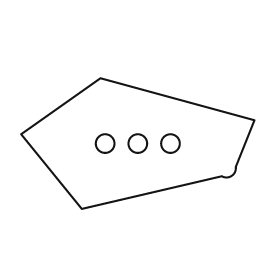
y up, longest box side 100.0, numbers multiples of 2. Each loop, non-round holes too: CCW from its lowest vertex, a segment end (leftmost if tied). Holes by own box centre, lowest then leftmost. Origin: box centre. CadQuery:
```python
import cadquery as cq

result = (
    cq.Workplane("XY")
    .moveTo(-24.0, -28.0)
    .lineTo(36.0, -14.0)
    .threePointArc((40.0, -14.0), (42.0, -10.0))
    .lineTo(50.0, 10.0)
    .lineTo(-16.0, 28.0)
    .lineTo(-50.0, 4.0)
    .close()
    .moveTo(-14.0, 0.0)
    .circle(4.0)
    .moveTo(0.0, 0.0)
    .circle(4.0)
    .moveTo(14.0, 0.0)
    .circle(4.0)
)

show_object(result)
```